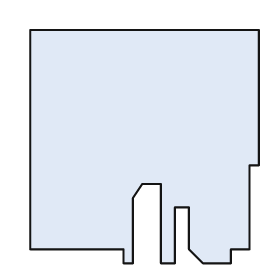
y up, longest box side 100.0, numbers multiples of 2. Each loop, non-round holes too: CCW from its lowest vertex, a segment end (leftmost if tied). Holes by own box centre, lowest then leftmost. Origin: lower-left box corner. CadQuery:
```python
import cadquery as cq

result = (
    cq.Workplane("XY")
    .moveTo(40.0, 0.0)
    .lineTo(44.0, 0.0)
    .lineTo(44.0, 28.0)
    .lineTo(48.0, 34.0)
    .lineTo(56.0, 34.0)
    .lineTo(56.0, 0.0)
    .lineTo(62.0, 0.0)
    .lineTo(62.0, 24.0)
    .lineTo(68.0, 24.0)
    .lineTo(68.0, 6.0)
    .lineTo(74.0, 0.0)
    .lineTo(86.0, 0.0)
    .lineTo(86.0, 6.0)
    .lineTo(94.0, 6.0)
    .lineTo(94.0, 42.0)
    .lineTo(98.0, 42.0)
    .lineTo(98.0, 100.0)
    .lineTo(0.0, 100.0)
    .lineTo(0.0, 6.0)
    .lineTo(40.0, 6.0)
    .close()
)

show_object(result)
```